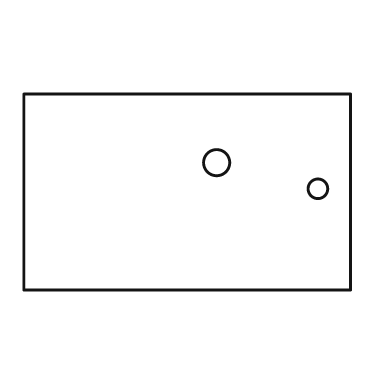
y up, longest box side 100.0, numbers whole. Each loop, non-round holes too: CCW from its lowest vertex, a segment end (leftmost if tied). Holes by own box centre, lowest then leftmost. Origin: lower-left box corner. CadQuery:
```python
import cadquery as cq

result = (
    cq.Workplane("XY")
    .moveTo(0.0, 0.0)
    .lineTo(100.0, 0.0)
    .lineTo(100.0, 60.0)
    .lineTo(0.0, 60.0)
    .close()
    .moveTo(90.0, 31.0)
    .circle(3.0)
    .moveTo(59.0, 39.0)
    .circle(4.0)
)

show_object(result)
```